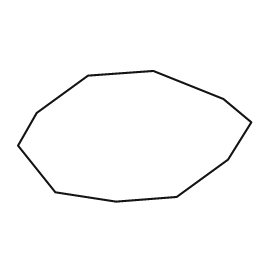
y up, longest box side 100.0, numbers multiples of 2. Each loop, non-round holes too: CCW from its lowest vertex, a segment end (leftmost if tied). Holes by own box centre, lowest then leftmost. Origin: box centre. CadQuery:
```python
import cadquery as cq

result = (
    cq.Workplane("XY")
    .moveTo(-8.0, -28.0)
    .lineTo(18.0, -26.0)
    .lineTo(40.0, -10.0)
    .lineTo(50.0, 6.0)
    .lineTo(38.0, 16.0)
    .lineTo(8.0, 28.0)
    .lineTo(-20.0, 26.0)
    .lineTo(-42.0, 10.0)
    .lineTo(-50.0, -4.0)
    .lineTo(-34.0, -24.0)
    .close()
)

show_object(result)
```